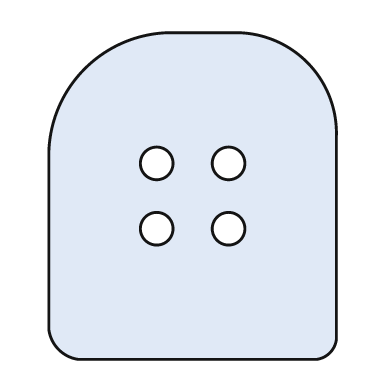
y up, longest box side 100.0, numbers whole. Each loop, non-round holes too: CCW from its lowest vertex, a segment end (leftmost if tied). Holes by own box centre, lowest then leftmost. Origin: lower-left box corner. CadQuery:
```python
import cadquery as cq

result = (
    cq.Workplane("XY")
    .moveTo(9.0, 0.0)
    .lineTo(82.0, 0.0)
    .threePointArc((86.0, 2.0), (88.0, 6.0))
    .lineTo(88.0, 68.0)
    .threePointArc((79.0, 91.0), (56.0, 100.0))
    .lineTo(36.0, 100.0)
    .threePointArc((11.0, 89.0), (0.0, 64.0))
    .lineTo(0.0, 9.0)
    .threePointArc((3.0, 3.0), (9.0, 0.0))
    .close()
    .moveTo(33.0, 40.0)
    .circle(5.0)
    .moveTo(55.0, 40.0)
    .circle(5.0)
    .moveTo(33.0, 60.0)
    .circle(5.0)
    .moveTo(55.0, 60.0)
    .circle(5.0)
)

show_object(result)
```